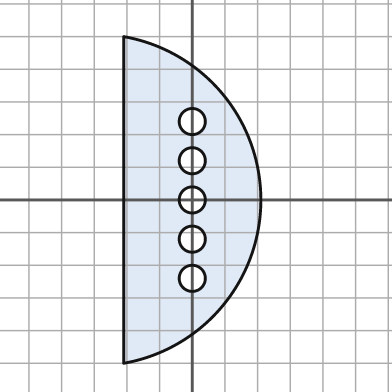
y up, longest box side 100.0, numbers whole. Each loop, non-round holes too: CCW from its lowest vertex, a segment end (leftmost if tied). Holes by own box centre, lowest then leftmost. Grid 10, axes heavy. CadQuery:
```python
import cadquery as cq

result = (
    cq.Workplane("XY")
    .moveTo(-21.0, -50.0)
    .threePointArc((21.0, 0.0), (-21.0, 50.0))
    .close()
    .moveTo(0.0, -24.0)
    .circle(4.0)
    .moveTo(0.0, -12.0)
    .circle(4.0)
    .moveTo(0.0, 0.0)
    .circle(4.0)
    .moveTo(0.0, 12.0)
    .circle(4.0)
    .moveTo(0.0, 24.0)
    .circle(4.0)
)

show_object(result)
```